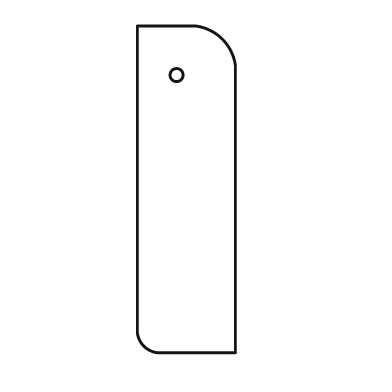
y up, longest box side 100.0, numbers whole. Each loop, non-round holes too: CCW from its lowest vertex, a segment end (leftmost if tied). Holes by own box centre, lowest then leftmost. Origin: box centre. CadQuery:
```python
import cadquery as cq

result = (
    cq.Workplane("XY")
    .moveTo(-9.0, -50.0)
    .lineTo(15.0, -50.0)
    .lineTo(15.0, 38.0)
    .threePointArc((11.0, 46.0), (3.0, 50.0))
    .lineTo(-15.0, 50.0)
    .lineTo(-15.0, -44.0)
    .threePointArc((-13.0, -48.0), (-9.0, -50.0))
    .close()
    .moveTo(-3.0, 35.0)
    .circle(2.0)
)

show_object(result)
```